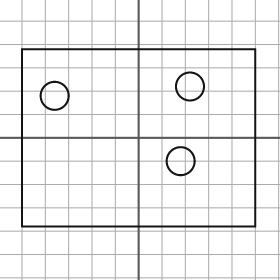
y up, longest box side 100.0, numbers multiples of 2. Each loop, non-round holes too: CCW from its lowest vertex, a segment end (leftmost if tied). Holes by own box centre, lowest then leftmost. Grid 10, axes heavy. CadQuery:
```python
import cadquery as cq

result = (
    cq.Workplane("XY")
    .moveTo(-50.0, -38.0)
    .lineTo(50.0, -38.0)
    .lineTo(50.0, 38.0)
    .lineTo(-50.0, 38.0)
    .close()
    .moveTo(18.0, -10.0)
    .circle(6.0)
    .moveTo(-36.0, 18.0)
    .circle(6.0)
    .moveTo(22.0, 22.0)
    .circle(6.0)
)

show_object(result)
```